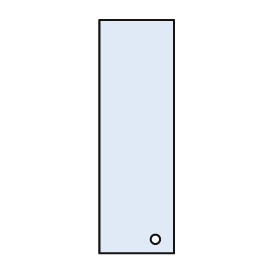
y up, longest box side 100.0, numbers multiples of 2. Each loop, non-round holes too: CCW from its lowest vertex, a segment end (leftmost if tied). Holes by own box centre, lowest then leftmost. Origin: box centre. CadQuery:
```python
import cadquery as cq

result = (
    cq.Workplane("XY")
    .moveTo(-16.0, -50.0)
    .lineTo(16.0, -50.0)
    .lineTo(16.0, 50.0)
    .lineTo(-16.0, 50.0)
    .close()
    .moveTo(8.0, -44.0)
    .circle(2.0)
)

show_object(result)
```